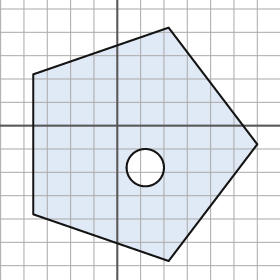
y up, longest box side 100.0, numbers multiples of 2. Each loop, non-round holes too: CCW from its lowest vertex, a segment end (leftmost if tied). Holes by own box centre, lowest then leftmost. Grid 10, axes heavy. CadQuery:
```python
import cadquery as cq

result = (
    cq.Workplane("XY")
    .moveTo(22.0, -58.0)
    .lineTo(60.0, -8.0)
    .lineTo(22.0, 42.0)
    .lineTo(-36.0, 22.0)
    .lineTo(-36.0, -38.0)
    .close()
    .moveTo(12.0, -18.0)
    .circle(8.0)
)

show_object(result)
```